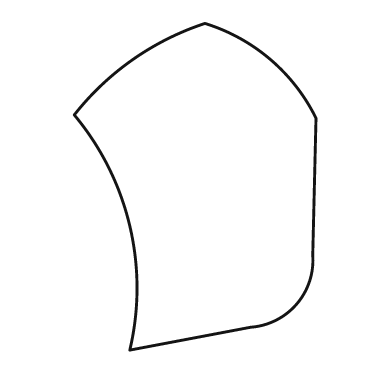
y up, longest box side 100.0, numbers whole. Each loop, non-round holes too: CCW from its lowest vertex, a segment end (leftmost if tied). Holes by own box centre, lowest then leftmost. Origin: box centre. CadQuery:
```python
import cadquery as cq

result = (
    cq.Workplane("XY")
    .moveTo(-20.0, -50.0)
    .lineTo(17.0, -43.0)
    .threePointArc((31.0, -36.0), (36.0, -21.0))
    .lineTo(37.0, 21.0)
    .threePointArc((23.0, 39.0), (3.0, 50.0))
    .threePointArc((-19.0, 39.0), (-37.0, 22.0))
    .threePointArc((-20.0, -12.0), (-20.0, -50.0))
    .close()
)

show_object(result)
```